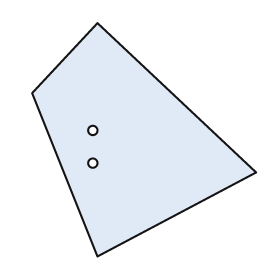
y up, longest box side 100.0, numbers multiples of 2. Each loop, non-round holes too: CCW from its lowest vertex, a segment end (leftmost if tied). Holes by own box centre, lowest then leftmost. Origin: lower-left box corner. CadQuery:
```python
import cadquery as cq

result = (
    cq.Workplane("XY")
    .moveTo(28.0, 0.0)
    .lineTo(96.0, 36.0)
    .lineTo(28.0, 100.0)
    .lineTo(0.0, 70.0)
    .close()
    .moveTo(26.0, 40.0)
    .circle(2.0)
    .moveTo(26.0, 54.0)
    .circle(2.0)
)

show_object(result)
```